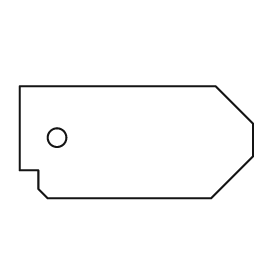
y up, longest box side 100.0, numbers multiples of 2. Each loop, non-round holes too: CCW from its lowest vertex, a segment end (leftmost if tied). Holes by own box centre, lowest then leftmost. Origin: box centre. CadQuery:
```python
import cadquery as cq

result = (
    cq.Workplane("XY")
    .moveTo(-38.0, -24.0)
    .lineTo(32.0, -24.0)
    .lineTo(50.0, -6.0)
    .lineTo(50.0, 8.0)
    .lineTo(34.0, 24.0)
    .lineTo(-50.0, 24.0)
    .lineTo(-50.0, -12.0)
    .lineTo(-42.0, -12.0)
    .lineTo(-42.0, -20.0)
    .close()
    .moveTo(-34.0, 2.0)
    .circle(4.0)
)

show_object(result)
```